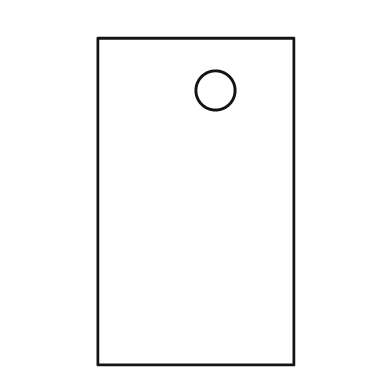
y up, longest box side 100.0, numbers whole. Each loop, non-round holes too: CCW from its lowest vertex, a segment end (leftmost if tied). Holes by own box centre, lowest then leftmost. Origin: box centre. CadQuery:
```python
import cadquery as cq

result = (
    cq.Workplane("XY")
    .moveTo(-30.0, -50.0)
    .lineTo(30.0, -50.0)
    .lineTo(30.0, 50.0)
    .lineTo(-30.0, 50.0)
    .close()
    .moveTo(6.0, 34.0)
    .circle(6.0)
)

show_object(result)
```